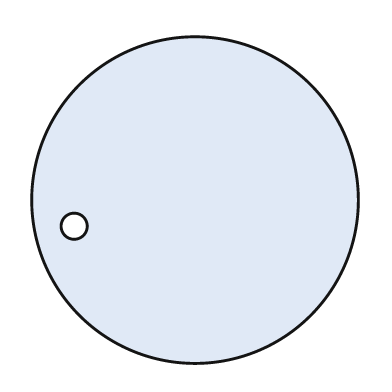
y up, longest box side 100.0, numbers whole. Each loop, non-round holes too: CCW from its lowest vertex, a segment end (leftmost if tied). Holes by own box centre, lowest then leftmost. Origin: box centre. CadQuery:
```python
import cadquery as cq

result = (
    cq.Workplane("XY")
    .moveTo(0.0, 0.0)
    .circle(50.0)
    .moveTo(-37.0, -8.0)
    .circle(4.0)
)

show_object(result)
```